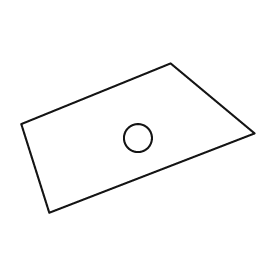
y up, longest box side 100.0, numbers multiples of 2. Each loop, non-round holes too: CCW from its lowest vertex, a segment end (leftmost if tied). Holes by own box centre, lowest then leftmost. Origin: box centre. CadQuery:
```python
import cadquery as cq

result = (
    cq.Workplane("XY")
    .moveTo(-38.0, -32.0)
    .lineTo(50.0, 2.0)
    .lineTo(14.0, 32.0)
    .lineTo(-50.0, 6.0)
    .close()
    .moveTo(0.0, 0.0)
    .circle(6.0)
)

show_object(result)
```